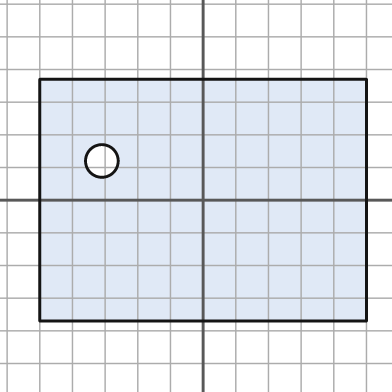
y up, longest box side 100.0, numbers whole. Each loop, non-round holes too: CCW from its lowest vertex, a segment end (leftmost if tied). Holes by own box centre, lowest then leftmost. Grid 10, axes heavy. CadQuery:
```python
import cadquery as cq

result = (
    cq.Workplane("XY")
    .moveTo(-50.0, -37.0)
    .lineTo(50.0, -37.0)
    .lineTo(50.0, 37.0)
    .lineTo(-50.0, 37.0)
    .close()
    .moveTo(-31.0, 12.0)
    .circle(5.0)
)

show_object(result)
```